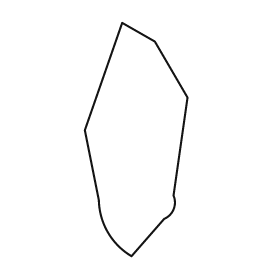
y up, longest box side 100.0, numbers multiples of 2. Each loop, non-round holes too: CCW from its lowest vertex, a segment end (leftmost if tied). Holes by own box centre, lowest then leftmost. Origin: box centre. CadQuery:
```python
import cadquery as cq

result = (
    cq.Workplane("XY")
    .moveTo(-2.0, -50.0)
    .lineTo(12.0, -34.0)
    .threePointArc((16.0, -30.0), (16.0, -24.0))
    .lineTo(22.0, 18.0)
    .lineTo(8.0, 42.0)
    .lineTo(-6.0, 50.0)
    .lineTo(-22.0, 4.0)
    .lineTo(-16.0, -26.0)
    .threePointArc((-12.0, -40.0), (-2.0, -50.0))
    .close()
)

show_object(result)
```